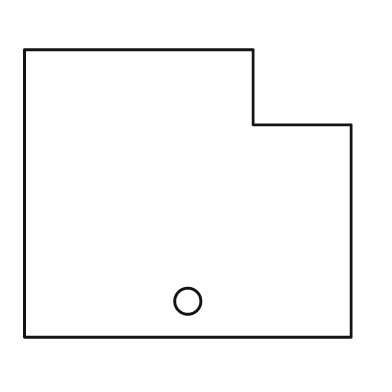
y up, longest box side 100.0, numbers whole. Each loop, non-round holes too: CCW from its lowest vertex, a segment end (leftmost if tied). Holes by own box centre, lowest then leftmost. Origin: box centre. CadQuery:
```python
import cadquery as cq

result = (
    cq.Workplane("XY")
    .moveTo(-50.0, -44.0)
    .lineTo(50.0, -44.0)
    .lineTo(50.0, 21.0)
    .lineTo(20.0, 21.0)
    .lineTo(20.0, 44.0)
    .lineTo(-50.0, 44.0)
    .close()
    .moveTo(0.0, -33.0)
    .circle(4.0)
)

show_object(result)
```